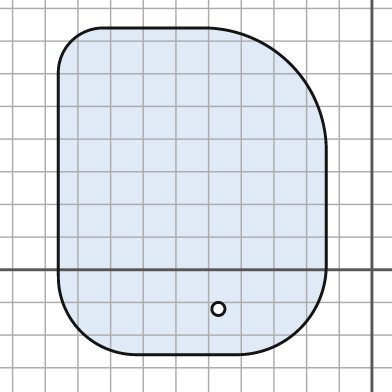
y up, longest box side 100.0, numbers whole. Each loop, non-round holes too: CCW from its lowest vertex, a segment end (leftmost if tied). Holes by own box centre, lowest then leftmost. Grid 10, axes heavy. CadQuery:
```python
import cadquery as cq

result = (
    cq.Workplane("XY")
    .moveTo(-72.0, -26.0)
    .lineTo(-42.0, -26.0)
    .threePointArc((-22.0, -18.0), (-14.0, 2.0))
    .lineTo(-14.0, 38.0)
    .threePointArc((-25.0, 63.0), (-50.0, 74.0))
    .lineTo(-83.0, 74.0)
    .threePointArc((-92.0, 70.0), (-96.0, 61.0))
    .lineTo(-96.0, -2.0)
    .threePointArc((-89.0, -19.0), (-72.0, -26.0))
    .close()
    .moveTo(-47.0, -12.0)
    .circle(2.0)
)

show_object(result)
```